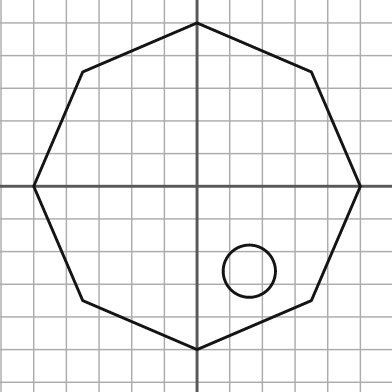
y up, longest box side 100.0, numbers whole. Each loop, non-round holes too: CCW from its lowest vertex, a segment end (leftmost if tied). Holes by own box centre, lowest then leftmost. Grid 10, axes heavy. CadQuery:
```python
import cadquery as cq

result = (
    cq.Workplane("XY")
    .moveTo(0.0, -50.0)
    .lineTo(35.0, -35.0)
    .lineTo(50.0, 0.0)
    .lineTo(35.0, 35.0)
    .lineTo(0.0, 50.0)
    .lineTo(-35.0, 35.0)
    .lineTo(-50.0, 0.0)
    .lineTo(-35.0, -35.0)
    .close()
    .moveTo(16.0, -26.0)
    .circle(8.0)
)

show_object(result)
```